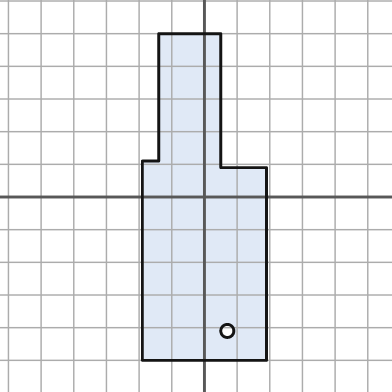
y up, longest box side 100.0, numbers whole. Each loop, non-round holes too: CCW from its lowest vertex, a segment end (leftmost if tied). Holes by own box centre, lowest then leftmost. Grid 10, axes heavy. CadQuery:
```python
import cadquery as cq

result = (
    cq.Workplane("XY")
    .moveTo(-19.0, -50.0)
    .lineTo(19.0, -50.0)
    .lineTo(19.0, 9.0)
    .lineTo(5.0, 9.0)
    .lineTo(5.0, 50.0)
    .lineTo(-14.0, 50.0)
    .lineTo(-14.0, 11.0)
    .lineTo(-19.0, 11.0)
    .close()
    .moveTo(7.0, -41.0)
    .circle(2.0)
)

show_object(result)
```